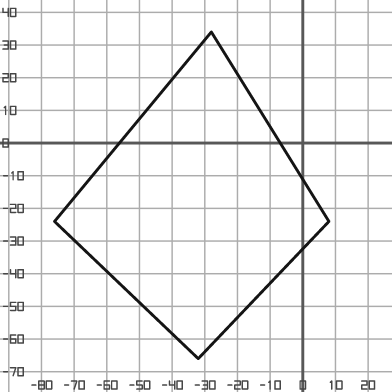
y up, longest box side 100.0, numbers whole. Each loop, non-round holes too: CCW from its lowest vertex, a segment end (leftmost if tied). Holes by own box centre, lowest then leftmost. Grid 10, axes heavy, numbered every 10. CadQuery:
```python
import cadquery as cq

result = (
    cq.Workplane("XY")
    .moveTo(-32.0, -66.0)
    .lineTo(8.0, -24.0)
    .lineTo(-28.0, 34.0)
    .lineTo(-76.0, -24.0)
    .close()
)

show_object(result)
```